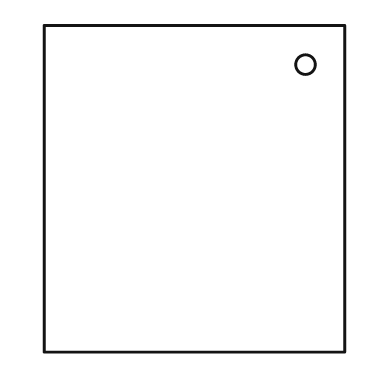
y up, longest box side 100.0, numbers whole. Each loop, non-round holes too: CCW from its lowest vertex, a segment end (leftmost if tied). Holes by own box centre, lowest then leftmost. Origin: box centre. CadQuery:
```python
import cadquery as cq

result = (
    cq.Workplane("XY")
    .moveTo(-46.0, -50.0)
    .lineTo(46.0, -50.0)
    .lineTo(46.0, 50.0)
    .lineTo(-46.0, 50.0)
    .close()
    .moveTo(34.0, 38.0)
    .circle(3.0)
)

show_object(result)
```